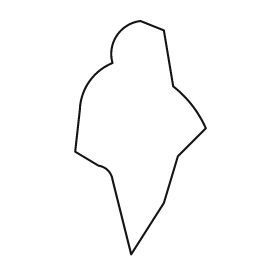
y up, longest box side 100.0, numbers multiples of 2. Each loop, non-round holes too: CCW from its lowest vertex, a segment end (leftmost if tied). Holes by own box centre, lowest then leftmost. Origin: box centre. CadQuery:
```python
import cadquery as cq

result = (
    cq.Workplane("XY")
    .moveTo(-4.0, -50.0)
    .lineTo(10.0, -28.0)
    .lineTo(16.0, -8.0)
    .lineTo(28.0, 4.0)
    .threePointArc((22.0, 14.0), (14.0, 22.0))
    .lineTo(10.0, 46.0)
    .lineTo(0.0, 50.0)
    .threePointArc((-10.0, 44.0), (-12.0, 32.0))
    .threePointArc((-22.0, 24.0), (-26.0, 12.0))
    .lineTo(-28.0, -6.0)
    .lineTo(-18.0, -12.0)
    .threePointArc((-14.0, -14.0), (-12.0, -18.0))
    .close()
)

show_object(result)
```